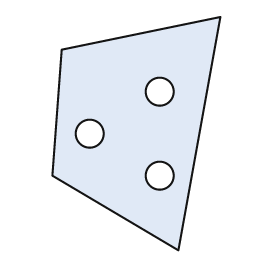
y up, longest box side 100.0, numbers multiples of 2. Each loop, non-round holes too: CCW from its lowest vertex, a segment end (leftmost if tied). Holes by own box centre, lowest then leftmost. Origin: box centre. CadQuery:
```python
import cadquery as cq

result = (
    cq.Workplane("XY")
    .moveTo(18.0, -50.0)
    .lineTo(36.0, 50.0)
    .lineTo(-32.0, 36.0)
    .lineTo(-36.0, -18.0)
    .close()
    .moveTo(10.0, -18.0)
    .circle(6.0)
    .moveTo(-20.0, 0.0)
    .circle(6.0)
    .moveTo(10.0, 18.0)
    .circle(6.0)
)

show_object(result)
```